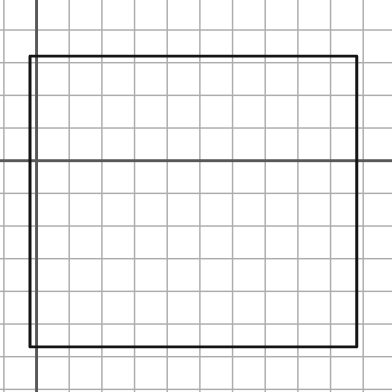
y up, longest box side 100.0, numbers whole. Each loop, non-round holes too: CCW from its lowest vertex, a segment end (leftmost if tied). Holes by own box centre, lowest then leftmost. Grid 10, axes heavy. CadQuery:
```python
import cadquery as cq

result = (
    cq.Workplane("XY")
    .moveTo(-2.0, -57.0)
    .lineTo(98.0, -57.0)
    .lineTo(98.0, 32.0)
    .lineTo(-2.0, 32.0)
    .close()
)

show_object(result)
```